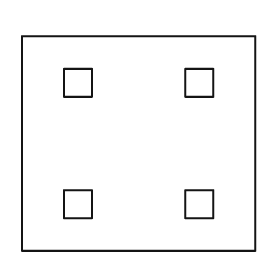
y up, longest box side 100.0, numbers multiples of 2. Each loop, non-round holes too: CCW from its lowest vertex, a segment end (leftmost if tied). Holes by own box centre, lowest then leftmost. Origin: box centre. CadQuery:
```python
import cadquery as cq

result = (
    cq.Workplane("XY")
    .moveTo(-50.0, -46.0)
    .lineTo(50.0, -46.0)
    .lineTo(50.0, 46.0)
    .lineTo(-50.0, 46.0)
    .close()
    .moveTo(-32.0, -32.0)
    .lineTo(-20.0, -32.0)
    .lineTo(-20.0, -20.0)
    .lineTo(-32.0, -20.0)
    .close()
    .moveTo(20.0, -32.0)
    .lineTo(32.0, -32.0)
    .lineTo(32.0, -20.0)
    .lineTo(20.0, -20.0)
    .close()
    .moveTo(-32.0, 20.0)
    .lineTo(-20.0, 20.0)
    .lineTo(-20.0, 32.0)
    .lineTo(-32.0, 32.0)
    .close()
    .moveTo(20.0, 20.0)
    .lineTo(32.0, 20.0)
    .lineTo(32.0, 32.0)
    .lineTo(20.0, 32.0)
    .close()
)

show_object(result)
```